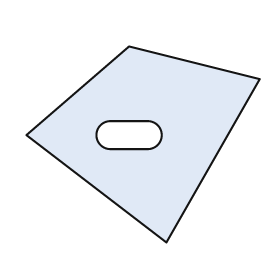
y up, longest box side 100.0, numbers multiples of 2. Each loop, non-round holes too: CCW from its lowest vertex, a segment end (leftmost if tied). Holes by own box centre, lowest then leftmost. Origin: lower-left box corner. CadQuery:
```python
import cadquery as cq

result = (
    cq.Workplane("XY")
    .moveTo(60.0, 0.0)
    .lineTo(100.0, 70.0)
    .lineTo(44.0, 84.0)
    .lineTo(0.0, 46.0)
    .close()
    .moveTo(36.0, 40.0)
    .lineTo(52.0, 40.0)
    .threePointArc((58.0, 46.0), (52.0, 52.0))
    .lineTo(36.0, 52.0)
    .threePointArc((30.0, 46.0), (36.0, 40.0))
    .close()
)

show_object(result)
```